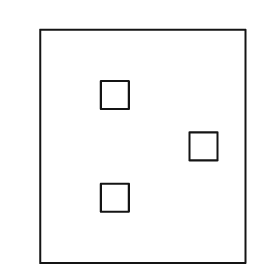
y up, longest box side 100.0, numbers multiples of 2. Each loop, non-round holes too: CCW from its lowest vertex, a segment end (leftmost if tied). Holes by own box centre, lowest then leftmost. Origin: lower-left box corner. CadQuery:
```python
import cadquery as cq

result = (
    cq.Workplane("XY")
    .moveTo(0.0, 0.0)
    .lineTo(88.0, 0.0)
    .lineTo(88.0, 100.0)
    .lineTo(0.0, 100.0)
    .close()
    .moveTo(26.0, 22.0)
    .lineTo(38.0, 22.0)
    .lineTo(38.0, 34.0)
    .lineTo(26.0, 34.0)
    .close()
    .moveTo(64.0, 44.0)
    .lineTo(76.0, 44.0)
    .lineTo(76.0, 56.0)
    .lineTo(64.0, 56.0)
    .close()
    .moveTo(26.0, 66.0)
    .lineTo(38.0, 66.0)
    .lineTo(38.0, 78.0)
    .lineTo(26.0, 78.0)
    .close()
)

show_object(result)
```